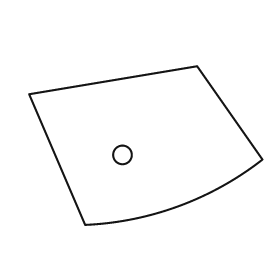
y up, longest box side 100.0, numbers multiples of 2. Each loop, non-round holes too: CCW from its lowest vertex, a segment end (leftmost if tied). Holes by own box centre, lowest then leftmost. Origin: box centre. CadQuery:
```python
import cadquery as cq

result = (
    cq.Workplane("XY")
    .moveTo(-26.0, -34.0)
    .threePointArc((14.0, -26.0), (50.0, -6.0))
    .lineTo(22.0, 34.0)
    .lineTo(-50.0, 22.0)
    .close()
    .moveTo(-10.0, -4.0)
    .circle(4.0)
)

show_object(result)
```